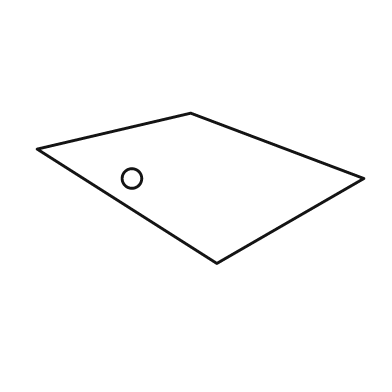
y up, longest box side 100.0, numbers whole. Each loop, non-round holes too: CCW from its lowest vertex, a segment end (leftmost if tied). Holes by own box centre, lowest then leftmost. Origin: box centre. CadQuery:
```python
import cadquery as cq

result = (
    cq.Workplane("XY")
    .moveTo(5.0, -23.0)
    .lineTo(50.0, 3.0)
    .lineTo(-3.0, 23.0)
    .lineTo(-50.0, 12.0)
    .close()
    .moveTo(-21.0, 3.0)
    .circle(3.0)
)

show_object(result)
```